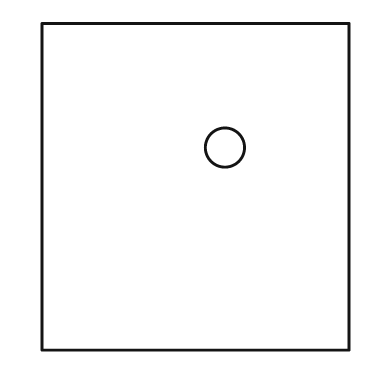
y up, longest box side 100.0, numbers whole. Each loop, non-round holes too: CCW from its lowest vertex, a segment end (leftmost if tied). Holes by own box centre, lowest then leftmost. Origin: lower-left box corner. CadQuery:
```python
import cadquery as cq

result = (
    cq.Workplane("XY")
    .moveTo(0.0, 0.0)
    .lineTo(94.0, 0.0)
    .lineTo(94.0, 100.0)
    .lineTo(0.0, 100.0)
    .close()
    .moveTo(56.0, 62.0)
    .circle(6.0)
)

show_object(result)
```